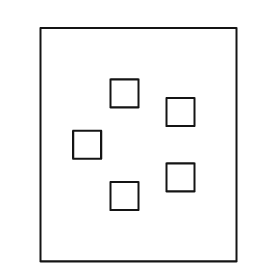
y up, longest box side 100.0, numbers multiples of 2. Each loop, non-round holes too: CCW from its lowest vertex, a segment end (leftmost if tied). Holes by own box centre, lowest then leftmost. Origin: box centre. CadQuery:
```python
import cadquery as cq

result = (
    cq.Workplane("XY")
    .moveTo(-42.0, -50.0)
    .lineTo(42.0, -50.0)
    .lineTo(42.0, 50.0)
    .lineTo(-42.0, 50.0)
    .close()
    .moveTo(-12.0, -28.0)
    .lineTo(0.0, -28.0)
    .lineTo(0.0, -16.0)
    .lineTo(-12.0, -16.0)
    .close()
    .moveTo(12.0, -20.0)
    .lineTo(24.0, -20.0)
    .lineTo(24.0, -8.0)
    .lineTo(12.0, -8.0)
    .close()
    .moveTo(-28.0, -6.0)
    .lineTo(-16.0, -6.0)
    .lineTo(-16.0, 6.0)
    .lineTo(-28.0, 6.0)
    .close()
    .moveTo(12.0, 8.0)
    .lineTo(24.0, 8.0)
    .lineTo(24.0, 20.0)
    .lineTo(12.0, 20.0)
    .close()
    .moveTo(-12.0, 16.0)
    .lineTo(0.0, 16.0)
    .lineTo(0.0, 28.0)
    .lineTo(-12.0, 28.0)
    .close()
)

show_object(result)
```